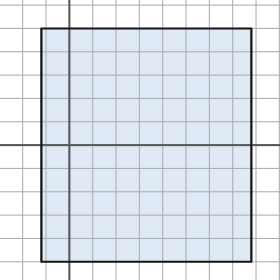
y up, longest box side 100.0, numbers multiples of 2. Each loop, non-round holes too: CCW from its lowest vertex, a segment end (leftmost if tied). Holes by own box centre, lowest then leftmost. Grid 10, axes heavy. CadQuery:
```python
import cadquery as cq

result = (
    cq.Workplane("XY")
    .moveTo(-12.0, -50.0)
    .lineTo(78.0, -50.0)
    .lineTo(78.0, 50.0)
    .lineTo(-12.0, 50.0)
    .close()
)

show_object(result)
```